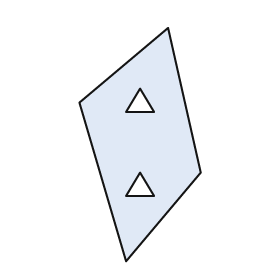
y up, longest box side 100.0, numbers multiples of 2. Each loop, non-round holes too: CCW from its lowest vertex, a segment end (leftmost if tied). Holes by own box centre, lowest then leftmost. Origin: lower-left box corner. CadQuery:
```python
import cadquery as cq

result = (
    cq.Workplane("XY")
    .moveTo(20.0, 0.0)
    .lineTo(52.0, 38.0)
    .lineTo(38.0, 100.0)
    .lineTo(0.0, 68.0)
    .close()
    .moveTo(20.0, 28.0)
    .lineTo(32.0, 28.0)
    .lineTo(26.0, 38.0)
    .close()
    .moveTo(20.0, 64.0)
    .lineTo(32.0, 64.0)
    .lineTo(26.0, 74.0)
    .close()
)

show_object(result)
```